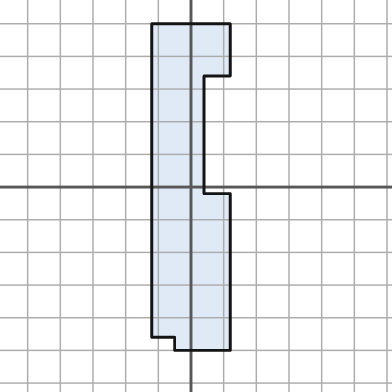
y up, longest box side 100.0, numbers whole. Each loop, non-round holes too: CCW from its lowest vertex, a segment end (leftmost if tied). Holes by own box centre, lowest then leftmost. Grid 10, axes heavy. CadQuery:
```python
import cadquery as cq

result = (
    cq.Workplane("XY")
    .moveTo(-5.0, -50.0)
    .lineTo(12.0, -50.0)
    .lineTo(12.0, -2.0)
    .lineTo(4.0, -2.0)
    .lineTo(4.0, 34.0)
    .lineTo(12.0, 34.0)
    .lineTo(12.0, 50.0)
    .lineTo(-12.0, 50.0)
    .lineTo(-12.0, -46.0)
    .lineTo(-5.0, -46.0)
    .close()
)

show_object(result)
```